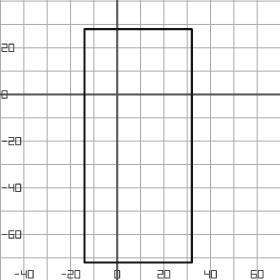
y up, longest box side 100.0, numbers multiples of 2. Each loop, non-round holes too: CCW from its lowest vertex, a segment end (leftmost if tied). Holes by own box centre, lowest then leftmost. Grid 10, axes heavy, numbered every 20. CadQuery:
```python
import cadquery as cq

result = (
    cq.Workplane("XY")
    .moveTo(-14.0, -72.0)
    .lineTo(32.0, -72.0)
    .lineTo(32.0, 28.0)
    .lineTo(-14.0, 28.0)
    .close()
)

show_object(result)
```